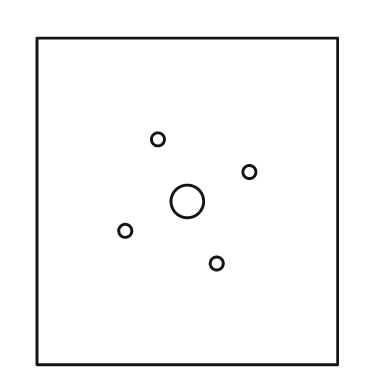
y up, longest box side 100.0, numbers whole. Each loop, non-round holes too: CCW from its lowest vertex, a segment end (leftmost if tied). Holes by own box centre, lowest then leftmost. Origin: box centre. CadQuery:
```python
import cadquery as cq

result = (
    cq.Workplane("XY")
    .moveTo(-46.0, -50.0)
    .lineTo(46.0, -50.0)
    .lineTo(46.0, 50.0)
    .lineTo(-46.0, 50.0)
    .close()
    .moveTo(9.0, -19.0)
    .circle(2.0)
    .moveTo(-19.0, -9.0)
    .circle(2.0)
    .moveTo(0.0, 0.0)
    .circle(5.0)
    .moveTo(19.0, 9.0)
    .circle(2.0)
    .moveTo(-9.0, 19.0)
    .circle(2.0)
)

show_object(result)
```